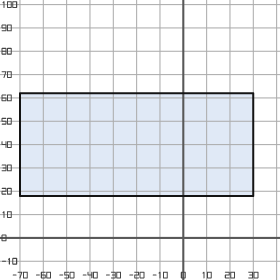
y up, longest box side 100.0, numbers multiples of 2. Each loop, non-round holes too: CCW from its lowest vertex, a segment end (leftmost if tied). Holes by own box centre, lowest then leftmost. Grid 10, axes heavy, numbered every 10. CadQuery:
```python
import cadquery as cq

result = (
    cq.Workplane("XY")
    .moveTo(-70.0, 18.0)
    .lineTo(30.0, 18.0)
    .lineTo(30.0, 62.0)
    .lineTo(-70.0, 62.0)
    .close()
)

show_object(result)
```